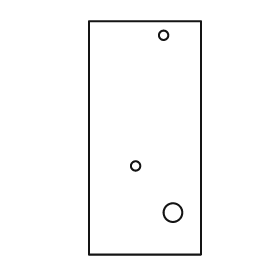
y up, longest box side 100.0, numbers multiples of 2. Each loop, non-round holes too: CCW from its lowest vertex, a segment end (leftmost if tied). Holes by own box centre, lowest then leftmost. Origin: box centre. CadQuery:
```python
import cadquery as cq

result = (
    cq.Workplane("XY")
    .moveTo(-24.0, -50.0)
    .lineTo(24.0, -50.0)
    .lineTo(24.0, 50.0)
    .lineTo(-24.0, 50.0)
    .close()
    .moveTo(12.0, -32.0)
    .circle(4.0)
    .moveTo(-4.0, -12.0)
    .circle(2.0)
    .moveTo(8.0, 44.0)
    .circle(2.0)
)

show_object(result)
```